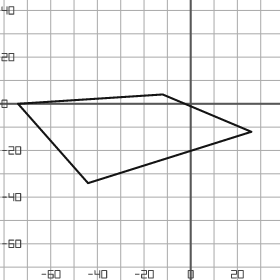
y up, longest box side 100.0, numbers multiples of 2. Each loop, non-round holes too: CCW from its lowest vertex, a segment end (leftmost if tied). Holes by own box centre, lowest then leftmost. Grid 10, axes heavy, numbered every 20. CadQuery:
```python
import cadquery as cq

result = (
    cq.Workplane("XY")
    .moveTo(-44.0, -34.0)
    .lineTo(26.0, -12.0)
    .lineTo(-12.0, 4.0)
    .lineTo(-74.0, 0.0)
    .close()
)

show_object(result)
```